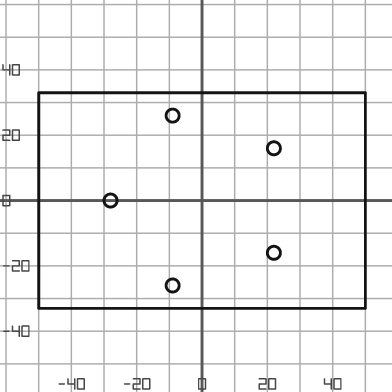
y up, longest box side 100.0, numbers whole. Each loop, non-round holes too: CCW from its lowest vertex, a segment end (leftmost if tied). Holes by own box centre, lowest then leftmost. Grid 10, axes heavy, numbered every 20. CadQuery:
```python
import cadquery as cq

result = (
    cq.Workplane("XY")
    .moveTo(-50.0, -33.0)
    .lineTo(50.0, -33.0)
    .lineTo(50.0, 33.0)
    .lineTo(-50.0, 33.0)
    .close()
    .moveTo(-9.0, -26.0)
    .circle(2.0)
    .moveTo(22.0, -16.0)
    .circle(2.0)
    .moveTo(-28.0, 0.0)
    .circle(2.0)
    .moveTo(22.0, 16.0)
    .circle(2.0)
    .moveTo(-9.0, 26.0)
    .circle(2.0)
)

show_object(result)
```